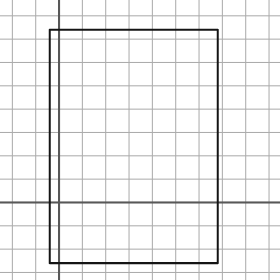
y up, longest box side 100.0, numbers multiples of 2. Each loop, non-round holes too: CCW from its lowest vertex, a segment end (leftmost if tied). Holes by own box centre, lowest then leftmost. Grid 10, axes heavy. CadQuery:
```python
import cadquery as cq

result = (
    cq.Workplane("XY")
    .moveTo(-4.0, -26.0)
    .lineTo(68.0, -26.0)
    .lineTo(68.0, 74.0)
    .lineTo(-4.0, 74.0)
    .close()
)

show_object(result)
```